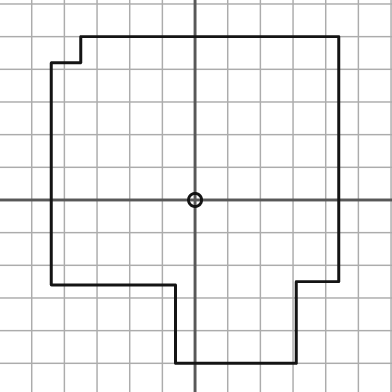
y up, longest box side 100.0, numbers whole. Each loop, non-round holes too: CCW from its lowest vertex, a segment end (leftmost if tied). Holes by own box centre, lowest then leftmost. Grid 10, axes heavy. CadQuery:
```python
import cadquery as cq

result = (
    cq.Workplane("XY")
    .moveTo(-6.0, -50.0)
    .lineTo(31.0, -50.0)
    .lineTo(31.0, -25.0)
    .lineTo(44.0, -25.0)
    .lineTo(44.0, 50.0)
    .lineTo(-35.0, 50.0)
    .lineTo(-35.0, 42.0)
    .lineTo(-44.0, 42.0)
    .lineTo(-44.0, -26.0)
    .lineTo(-6.0, -26.0)
    .close()
    .moveTo(0.0, 0.0)
    .circle(2.0)
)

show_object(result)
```